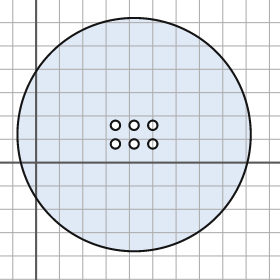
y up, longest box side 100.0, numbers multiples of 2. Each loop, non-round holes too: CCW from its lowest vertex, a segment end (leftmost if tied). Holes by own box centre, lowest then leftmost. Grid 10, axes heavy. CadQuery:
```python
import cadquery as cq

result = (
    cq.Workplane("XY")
    .moveTo(42.0, 12.0)
    .circle(50.0)
    .moveTo(34.0, 8.0)
    .circle(2.0)
    .moveTo(42.0, 8.0)
    .circle(2.0)
    .moveTo(50.0, 8.0)
    .circle(2.0)
    .moveTo(34.0, 16.0)
    .circle(2.0)
    .moveTo(42.0, 16.0)
    .circle(2.0)
    .moveTo(50.0, 16.0)
    .circle(2.0)
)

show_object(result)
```